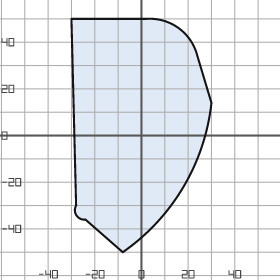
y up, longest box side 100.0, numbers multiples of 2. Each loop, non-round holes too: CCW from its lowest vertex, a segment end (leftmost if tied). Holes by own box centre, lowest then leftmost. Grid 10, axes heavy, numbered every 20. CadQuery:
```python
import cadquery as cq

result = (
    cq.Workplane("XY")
    .moveTo(-8.0, -50.0)
    .threePointArc((18.0, -22.0), (30.0, 14.0))
    .lineTo(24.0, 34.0)
    .threePointArc((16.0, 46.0), (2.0, 50.0))
    .lineTo(-30.0, 50.0)
    .lineTo(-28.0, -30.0)
    .threePointArc((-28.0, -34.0), (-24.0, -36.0))
    .close()
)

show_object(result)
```